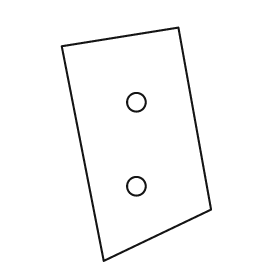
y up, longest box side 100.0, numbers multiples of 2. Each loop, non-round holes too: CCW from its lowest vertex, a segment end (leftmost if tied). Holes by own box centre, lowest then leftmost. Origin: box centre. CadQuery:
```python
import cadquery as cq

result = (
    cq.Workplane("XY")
    .moveTo(-14.0, -50.0)
    .lineTo(32.0, -28.0)
    .lineTo(18.0, 50.0)
    .lineTo(-32.0, 42.0)
    .close()
    .moveTo(0.0, -18.0)
    .circle(4.0)
    .moveTo(0.0, 18.0)
    .circle(4.0)
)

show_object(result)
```